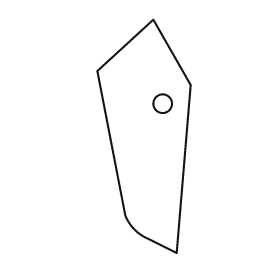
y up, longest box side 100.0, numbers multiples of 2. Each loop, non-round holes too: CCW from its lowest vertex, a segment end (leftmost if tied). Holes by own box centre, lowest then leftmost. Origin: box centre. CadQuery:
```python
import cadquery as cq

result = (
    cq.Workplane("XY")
    .moveTo(14.0, -50.0)
    .lineTo(20.0, 22.0)
    .lineTo(4.0, 50.0)
    .lineTo(-20.0, 28.0)
    .lineTo(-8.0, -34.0)
    .threePointArc((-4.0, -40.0), (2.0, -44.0))
    .close()
    .moveTo(8.0, 14.0)
    .circle(4.0)
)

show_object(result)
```